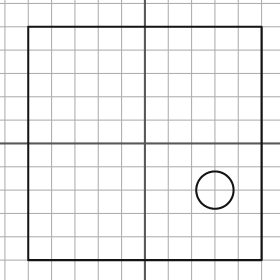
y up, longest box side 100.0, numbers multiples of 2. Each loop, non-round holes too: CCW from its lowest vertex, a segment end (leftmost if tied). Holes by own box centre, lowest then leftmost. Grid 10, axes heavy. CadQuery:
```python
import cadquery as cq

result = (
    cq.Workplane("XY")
    .moveTo(-50.0, -50.0)
    .lineTo(50.0, -50.0)
    .lineTo(50.0, 50.0)
    .lineTo(-50.0, 50.0)
    .close()
    .moveTo(30.0, -20.0)
    .circle(8.0)
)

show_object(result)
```